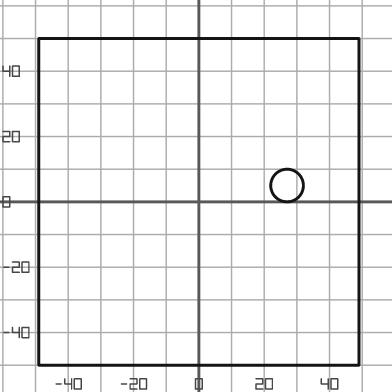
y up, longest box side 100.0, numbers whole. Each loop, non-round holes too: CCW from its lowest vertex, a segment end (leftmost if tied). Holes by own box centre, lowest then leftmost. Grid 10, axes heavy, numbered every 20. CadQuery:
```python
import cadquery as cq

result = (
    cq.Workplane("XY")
    .moveTo(-49.0, -50.0)
    .lineTo(49.0, -50.0)
    .lineTo(49.0, 50.0)
    .lineTo(-49.0, 50.0)
    .close()
    .moveTo(27.0, 5.0)
    .circle(5.0)
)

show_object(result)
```